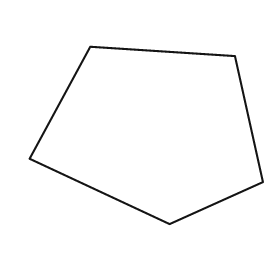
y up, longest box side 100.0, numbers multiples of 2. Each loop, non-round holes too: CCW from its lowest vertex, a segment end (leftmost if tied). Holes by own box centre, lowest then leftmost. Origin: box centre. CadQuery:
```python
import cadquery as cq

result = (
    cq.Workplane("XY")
    .moveTo(10.0, -38.0)
    .lineTo(50.0, -20.0)
    .lineTo(38.0, 34.0)
    .lineTo(-24.0, 38.0)
    .lineTo(-50.0, -10.0)
    .close()
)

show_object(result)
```